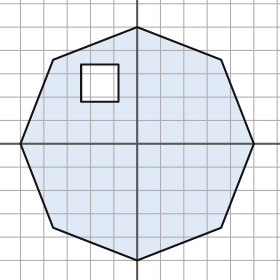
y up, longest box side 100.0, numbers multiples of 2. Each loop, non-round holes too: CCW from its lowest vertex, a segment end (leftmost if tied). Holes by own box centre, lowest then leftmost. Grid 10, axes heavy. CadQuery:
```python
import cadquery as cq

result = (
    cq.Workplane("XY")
    .moveTo(0.0, -50.0)
    .lineTo(36.0, -36.0)
    .lineTo(50.0, 0.0)
    .lineTo(36.0, 36.0)
    .lineTo(0.0, 50.0)
    .lineTo(-36.0, 36.0)
    .lineTo(-50.0, 0.0)
    .lineTo(-36.0, -36.0)
    .close()
    .moveTo(-24.0, 18.0)
    .lineTo(-8.0, 18.0)
    .lineTo(-8.0, 34.0)
    .lineTo(-24.0, 34.0)
    .close()
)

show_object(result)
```